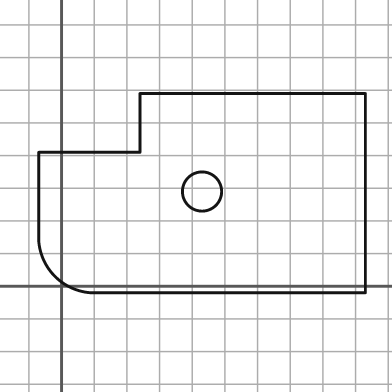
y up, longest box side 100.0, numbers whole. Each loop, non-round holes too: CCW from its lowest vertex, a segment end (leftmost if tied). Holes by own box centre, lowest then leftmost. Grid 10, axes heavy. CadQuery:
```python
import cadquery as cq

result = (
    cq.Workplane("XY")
    .moveTo(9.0, -2.0)
    .lineTo(93.0, -2.0)
    .lineTo(93.0, 59.0)
    .lineTo(24.0, 59.0)
    .lineTo(24.0, 41.0)
    .lineTo(-7.0, 41.0)
    .lineTo(-7.0, 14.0)
    .threePointArc((-2.0, 3.0), (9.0, -2.0))
    .close()
    .moveTo(43.0, 29.0)
    .circle(6.0)
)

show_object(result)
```